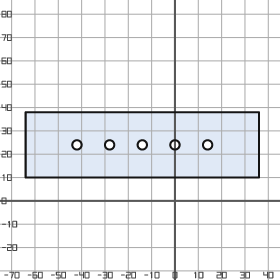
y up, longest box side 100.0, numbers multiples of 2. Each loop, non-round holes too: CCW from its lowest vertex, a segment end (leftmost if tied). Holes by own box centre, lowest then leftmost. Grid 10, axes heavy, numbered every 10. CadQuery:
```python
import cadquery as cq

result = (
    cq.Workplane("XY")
    .moveTo(-64.0, 10.0)
    .lineTo(36.0, 10.0)
    .lineTo(36.0, 38.0)
    .lineTo(-64.0, 38.0)
    .close()
    .moveTo(-42.0, 24.0)
    .circle(2.0)
    .moveTo(-28.0, 24.0)
    .circle(2.0)
    .moveTo(-14.0, 24.0)
    .circle(2.0)
    .moveTo(0.0, 24.0)
    .circle(2.0)
    .moveTo(14.0, 24.0)
    .circle(2.0)
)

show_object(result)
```